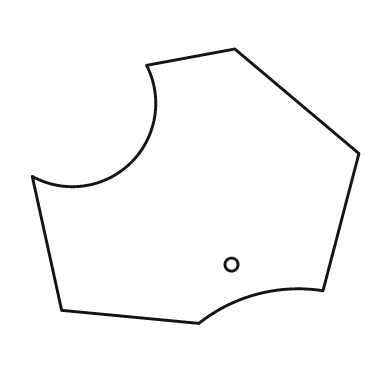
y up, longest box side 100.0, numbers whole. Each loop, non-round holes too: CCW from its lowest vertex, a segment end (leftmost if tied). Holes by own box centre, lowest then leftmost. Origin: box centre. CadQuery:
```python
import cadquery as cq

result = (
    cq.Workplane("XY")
    .moveTo(1.0, -42.0)
    .threePointArc((19.0, -33.0), (39.0, -32.0))
    .lineTo(50.0, 10.0)
    .lineTo(12.0, 42.0)
    .lineTo(-15.0, 37.0)
    .threePointArc((-20.0, 7.0), (-50.0, 3.0))
    .lineTo(-41.0, -38.0)
    .close()
    .moveTo(11.0, -24.0)
    .circle(2.0)
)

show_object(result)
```